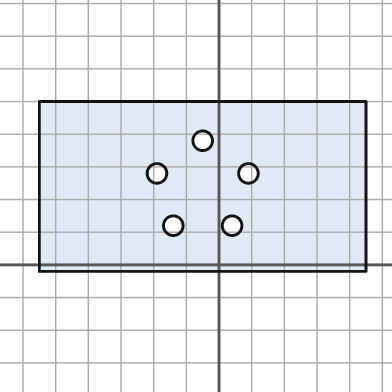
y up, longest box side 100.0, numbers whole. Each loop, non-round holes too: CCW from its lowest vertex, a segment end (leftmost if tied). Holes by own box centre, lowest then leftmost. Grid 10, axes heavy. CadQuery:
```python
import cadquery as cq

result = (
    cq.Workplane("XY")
    .moveTo(-55.0, -2.0)
    .lineTo(45.0, -2.0)
    .lineTo(45.0, 50.0)
    .lineTo(-55.0, 50.0)
    .close()
    .moveTo(-14.0, 12.0)
    .circle(3.0)
    .moveTo(4.0, 12.0)
    .circle(3.0)
    .moveTo(-19.0, 28.0)
    .circle(3.0)
    .moveTo(9.0, 28.0)
    .circle(3.0)
    .moveTo(-5.0, 38.0)
    .circle(3.0)
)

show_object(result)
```